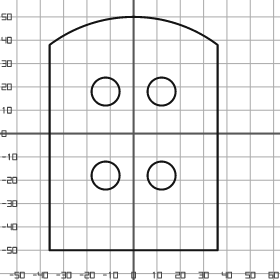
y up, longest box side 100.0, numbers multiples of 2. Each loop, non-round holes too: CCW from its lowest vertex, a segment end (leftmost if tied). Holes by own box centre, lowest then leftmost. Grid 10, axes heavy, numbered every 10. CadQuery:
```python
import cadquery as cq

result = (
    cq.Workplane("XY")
    .moveTo(-36.0, -50.0)
    .lineTo(36.0, -50.0)
    .lineTo(36.0, 38.0)
    .threePointArc((0.0, 50.0), (-36.0, 38.0))
    .close()
    .moveTo(-12.0, -18.0)
    .circle(6.0)
    .moveTo(12.0, -18.0)
    .circle(6.0)
    .moveTo(-12.0, 18.0)
    .circle(6.0)
    .moveTo(12.0, 18.0)
    .circle(6.0)
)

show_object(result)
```